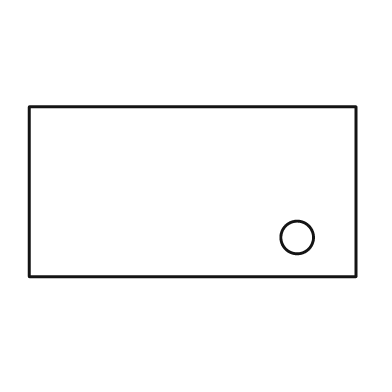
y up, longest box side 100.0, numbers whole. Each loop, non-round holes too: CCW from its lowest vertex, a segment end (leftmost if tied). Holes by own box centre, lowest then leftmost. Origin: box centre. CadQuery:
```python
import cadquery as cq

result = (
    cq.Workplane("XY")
    .moveTo(-50.0, -26.0)
    .lineTo(50.0, -26.0)
    .lineTo(50.0, 26.0)
    .lineTo(-50.0, 26.0)
    .close()
    .moveTo(32.0, -14.0)
    .circle(5.0)
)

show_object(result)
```